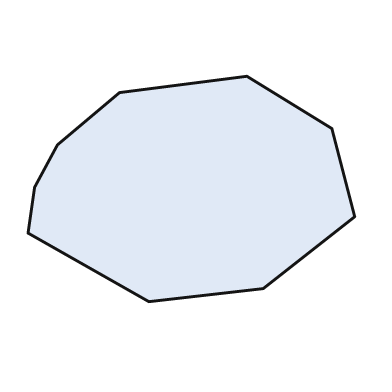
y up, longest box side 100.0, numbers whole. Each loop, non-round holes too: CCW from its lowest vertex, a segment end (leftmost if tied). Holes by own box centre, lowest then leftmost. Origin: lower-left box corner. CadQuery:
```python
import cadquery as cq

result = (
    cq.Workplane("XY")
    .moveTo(37.0, 0.0)
    .lineTo(72.0, 4.0)
    .lineTo(100.0, 26.0)
    .lineTo(93.0, 53.0)
    .lineTo(67.0, 69.0)
    .lineTo(28.0, 64.0)
    .lineTo(9.0, 48.0)
    .lineTo(2.0, 35.0)
    .lineTo(0.0, 21.0)
    .close()
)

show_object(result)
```